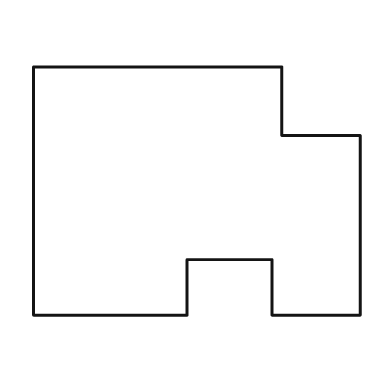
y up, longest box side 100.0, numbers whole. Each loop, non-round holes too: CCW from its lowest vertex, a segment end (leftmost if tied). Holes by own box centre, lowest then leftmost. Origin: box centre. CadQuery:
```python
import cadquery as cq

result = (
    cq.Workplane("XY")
    .moveTo(-50.0, -38.0)
    .lineTo(-3.0, -38.0)
    .lineTo(-3.0, -21.0)
    .lineTo(23.0, -21.0)
    .lineTo(23.0, -38.0)
    .lineTo(50.0, -38.0)
    .lineTo(50.0, 17.0)
    .lineTo(26.0, 17.0)
    .lineTo(26.0, 38.0)
    .lineTo(-50.0, 38.0)
    .close()
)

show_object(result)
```